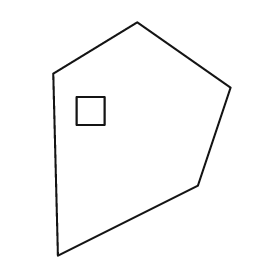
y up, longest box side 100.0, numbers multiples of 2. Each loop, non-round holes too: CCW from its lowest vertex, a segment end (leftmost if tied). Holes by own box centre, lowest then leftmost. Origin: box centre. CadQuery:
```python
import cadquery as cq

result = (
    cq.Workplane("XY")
    .moveTo(-36.0, -50.0)
    .lineTo(24.0, -20.0)
    .lineTo(38.0, 22.0)
    .lineTo(-2.0, 50.0)
    .lineTo(-38.0, 28.0)
    .close()
    .moveTo(-28.0, 6.0)
    .lineTo(-16.0, 6.0)
    .lineTo(-16.0, 18.0)
    .lineTo(-28.0, 18.0)
    .close()
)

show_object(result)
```